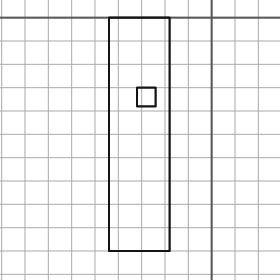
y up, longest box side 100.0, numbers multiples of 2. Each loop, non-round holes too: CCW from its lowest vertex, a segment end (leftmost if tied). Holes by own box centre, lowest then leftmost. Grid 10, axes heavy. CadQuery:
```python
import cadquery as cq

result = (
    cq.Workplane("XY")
    .moveTo(-44.0, -100.0)
    .lineTo(-18.0, -100.0)
    .lineTo(-18.0, 0.0)
    .lineTo(-44.0, 0.0)
    .close()
    .moveTo(-32.0, -38.0)
    .lineTo(-24.0, -38.0)
    .lineTo(-24.0, -30.0)
    .lineTo(-32.0, -30.0)
    .close()
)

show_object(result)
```